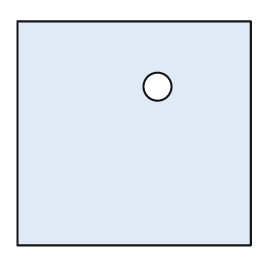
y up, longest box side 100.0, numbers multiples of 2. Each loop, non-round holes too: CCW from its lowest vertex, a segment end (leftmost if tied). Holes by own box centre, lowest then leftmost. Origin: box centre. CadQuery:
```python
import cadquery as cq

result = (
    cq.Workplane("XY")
    .moveTo(-50.0, -48.0)
    .lineTo(50.0, -48.0)
    .lineTo(50.0, 48.0)
    .lineTo(-50.0, 48.0)
    .close()
    .moveTo(10.0, 20.0)
    .circle(6.0)
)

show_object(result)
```